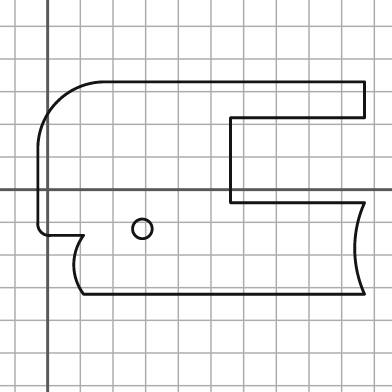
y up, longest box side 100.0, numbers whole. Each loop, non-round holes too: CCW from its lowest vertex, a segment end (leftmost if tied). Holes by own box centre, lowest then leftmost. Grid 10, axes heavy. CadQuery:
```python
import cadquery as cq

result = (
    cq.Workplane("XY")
    .moveTo(11.0, -32.0)
    .lineTo(97.0, -32.0)
    .threePointArc((94.0, -18.0), (97.0, -4.0))
    .lineTo(56.0, -4.0)
    .lineTo(56.0, 22.0)
    .lineTo(97.0, 22.0)
    .lineTo(97.0, 33.0)
    .lineTo(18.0, 33.0)
    .threePointArc((3.0, 27.0), (-3.0, 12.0))
    .lineTo(-3.0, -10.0)
    .threePointArc((-2.0, -13.0), (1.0, -14.0))
    .lineTo(11.0, -14.0)
    .threePointArc((8.0, -23.0), (11.0, -32.0))
    .close()
    .moveTo(29.0, -12.0)
    .circle(3.0)
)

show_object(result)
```